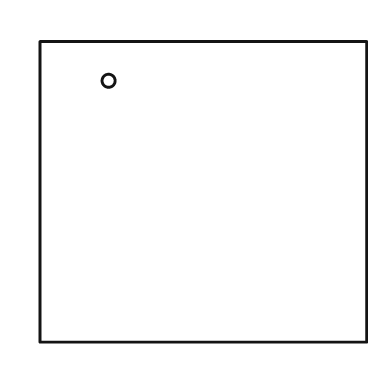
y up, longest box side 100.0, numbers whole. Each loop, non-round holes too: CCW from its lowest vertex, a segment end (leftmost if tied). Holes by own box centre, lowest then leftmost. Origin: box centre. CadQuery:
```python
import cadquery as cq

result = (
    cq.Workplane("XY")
    .moveTo(-50.0, -46.0)
    .lineTo(50.0, -46.0)
    .lineTo(50.0, 46.0)
    .lineTo(-50.0, 46.0)
    .close()
    .moveTo(-29.0, 34.0)
    .circle(2.0)
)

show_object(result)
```